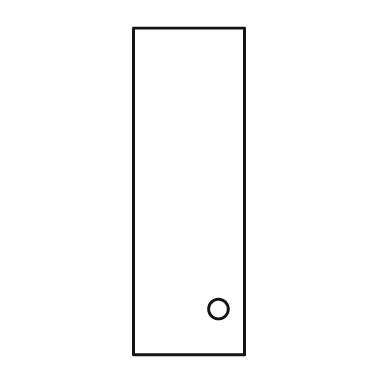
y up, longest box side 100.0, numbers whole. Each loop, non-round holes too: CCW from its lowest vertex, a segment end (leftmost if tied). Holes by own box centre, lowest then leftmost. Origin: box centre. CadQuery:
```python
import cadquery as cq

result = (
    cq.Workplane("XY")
    .moveTo(-17.0, -50.0)
    .lineTo(17.0, -50.0)
    .lineTo(17.0, 50.0)
    .lineTo(-17.0, 50.0)
    .close()
    .moveTo(9.0, -36.0)
    .circle(3.0)
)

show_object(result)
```